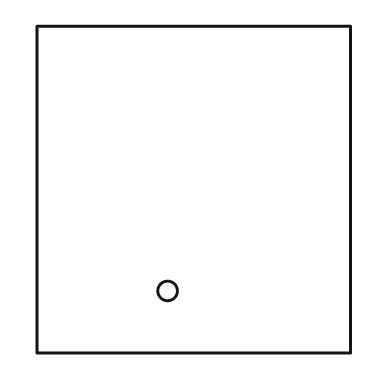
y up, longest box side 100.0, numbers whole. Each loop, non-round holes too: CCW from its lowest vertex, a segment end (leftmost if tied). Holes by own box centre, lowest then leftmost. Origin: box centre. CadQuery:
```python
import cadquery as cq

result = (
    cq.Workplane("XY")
    .moveTo(-48.0, -50.0)
    .lineTo(48.0, -50.0)
    .lineTo(48.0, 50.0)
    .lineTo(-48.0, 50.0)
    .close()
    .moveTo(-8.0, -31.0)
    .circle(3.0)
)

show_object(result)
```